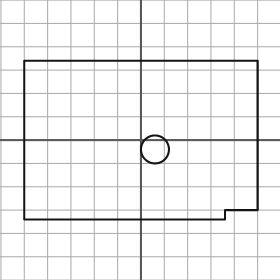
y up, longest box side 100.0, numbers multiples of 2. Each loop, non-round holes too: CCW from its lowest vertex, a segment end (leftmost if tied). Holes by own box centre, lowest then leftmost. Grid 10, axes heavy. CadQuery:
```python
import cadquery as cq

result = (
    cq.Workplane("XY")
    .moveTo(-50.0, -34.0)
    .lineTo(36.0, -34.0)
    .lineTo(36.0, -30.0)
    .lineTo(50.0, -30.0)
    .lineTo(50.0, 34.0)
    .lineTo(-50.0, 34.0)
    .close()
    .moveTo(6.0, -4.0)
    .circle(6.0)
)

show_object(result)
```